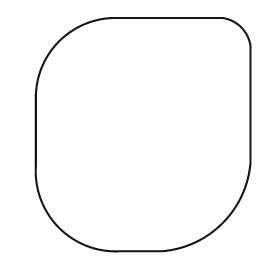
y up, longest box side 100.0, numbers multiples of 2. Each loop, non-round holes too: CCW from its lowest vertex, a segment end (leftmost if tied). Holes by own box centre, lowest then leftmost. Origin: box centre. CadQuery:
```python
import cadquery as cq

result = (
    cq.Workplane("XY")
    .moveTo(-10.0, -50.0)
    .lineTo(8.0, -50.0)
    .threePointArc((34.0, -38.0), (46.0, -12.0))
    .lineTo(46.0, 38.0)
    .threePointArc((42.0, 46.0), (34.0, 50.0))
    .lineTo(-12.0, 50.0)
    .threePointArc((-36.0, 40.0), (-46.0, 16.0))
    .lineTo(-46.0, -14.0)
    .threePointArc((-36.0, -40.0), (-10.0, -50.0))
    .close()
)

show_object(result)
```